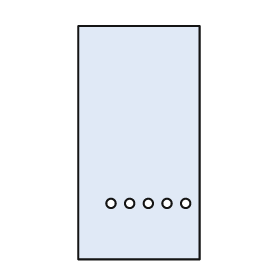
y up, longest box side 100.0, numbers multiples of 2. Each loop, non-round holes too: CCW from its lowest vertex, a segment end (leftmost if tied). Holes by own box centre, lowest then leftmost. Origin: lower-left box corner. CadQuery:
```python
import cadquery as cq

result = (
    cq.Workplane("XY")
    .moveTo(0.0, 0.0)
    .lineTo(52.0, 0.0)
    .lineTo(52.0, 100.0)
    .lineTo(0.0, 100.0)
    .close()
    .moveTo(14.0, 24.0)
    .circle(2.0)
    .moveTo(22.0, 24.0)
    .circle(2.0)
    .moveTo(30.0, 24.0)
    .circle(2.0)
    .moveTo(38.0, 24.0)
    .circle(2.0)
    .moveTo(46.0, 24.0)
    .circle(2.0)
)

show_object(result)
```